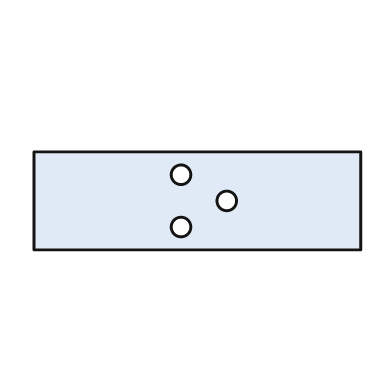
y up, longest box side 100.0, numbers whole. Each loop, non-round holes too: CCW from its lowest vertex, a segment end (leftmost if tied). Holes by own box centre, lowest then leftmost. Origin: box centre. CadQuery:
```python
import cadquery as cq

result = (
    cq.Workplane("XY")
    .moveTo(-50.0, -15.0)
    .lineTo(50.0, -15.0)
    .lineTo(50.0, 15.0)
    .lineTo(-50.0, 15.0)
    .close()
    .moveTo(-5.0, -8.0)
    .circle(3.0)
    .moveTo(9.0, 0.0)
    .circle(3.0)
    .moveTo(-5.0, 8.0)
    .circle(3.0)
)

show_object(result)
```